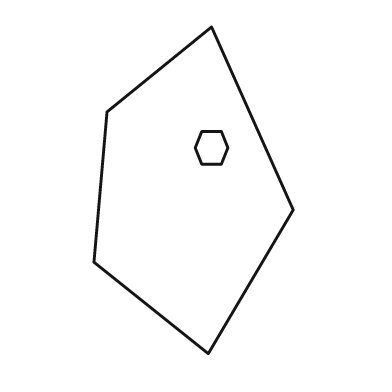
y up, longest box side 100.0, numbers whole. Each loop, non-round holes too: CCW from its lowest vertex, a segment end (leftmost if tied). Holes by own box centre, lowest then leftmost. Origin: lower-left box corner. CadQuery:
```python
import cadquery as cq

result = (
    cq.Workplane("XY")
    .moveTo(35.0, 0.0)
    .lineTo(61.0, 44.0)
    .lineTo(36.0, 100.0)
    .lineTo(4.0, 74.0)
    .lineTo(0.0, 28.0)
    .close()
    .moveTo(33.0, 58.0)
    .lineTo(39.0, 58.0)
    .lineTo(41.0, 63.0)
    .lineTo(39.0, 68.0)
    .lineTo(33.0, 68.0)
    .lineTo(31.0, 63.0)
    .close()
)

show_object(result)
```